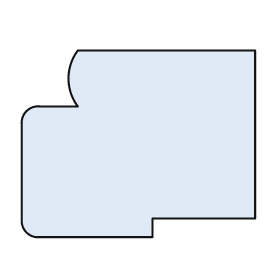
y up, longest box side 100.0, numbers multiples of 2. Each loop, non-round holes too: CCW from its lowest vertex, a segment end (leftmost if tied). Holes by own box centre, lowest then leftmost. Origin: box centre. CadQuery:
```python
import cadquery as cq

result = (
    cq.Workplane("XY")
    .moveTo(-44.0, -40.0)
    .lineTo(6.0, -40.0)
    .lineTo(6.0, -32.0)
    .lineTo(50.0, -32.0)
    .lineTo(50.0, 40.0)
    .lineTo(-26.0, 40.0)
    .threePointArc((-30.0, 28.0), (-26.0, 16.0))
    .lineTo(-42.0, 16.0)
    .threePointArc((-48.0, 14.0), (-50.0, 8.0))
    .lineTo(-50.0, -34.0)
    .threePointArc((-48.0, -38.0), (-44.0, -40.0))
    .close()
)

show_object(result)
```